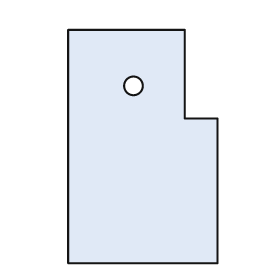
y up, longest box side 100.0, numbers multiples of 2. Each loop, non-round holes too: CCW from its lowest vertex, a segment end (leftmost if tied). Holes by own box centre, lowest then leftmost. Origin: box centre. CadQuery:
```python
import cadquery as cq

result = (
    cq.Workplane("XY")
    .moveTo(-32.0, -50.0)
    .lineTo(32.0, -50.0)
    .lineTo(32.0, 12.0)
    .lineTo(18.0, 12.0)
    .lineTo(18.0, 50.0)
    .lineTo(-32.0, 50.0)
    .close()
    .moveTo(-4.0, 26.0)
    .circle(4.0)
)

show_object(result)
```